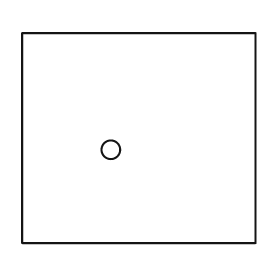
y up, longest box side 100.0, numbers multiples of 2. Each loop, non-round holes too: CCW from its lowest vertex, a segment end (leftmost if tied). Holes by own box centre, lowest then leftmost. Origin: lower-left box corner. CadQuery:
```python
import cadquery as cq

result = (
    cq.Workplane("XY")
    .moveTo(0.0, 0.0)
    .lineTo(100.0, 0.0)
    .lineTo(100.0, 90.0)
    .lineTo(0.0, 90.0)
    .close()
    .moveTo(38.0, 40.0)
    .circle(4.0)
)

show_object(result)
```